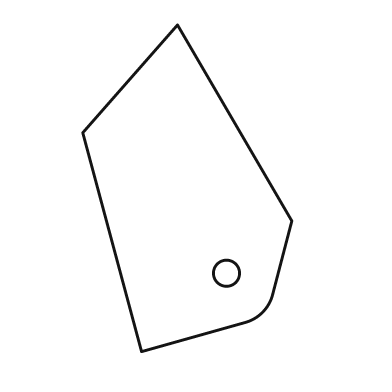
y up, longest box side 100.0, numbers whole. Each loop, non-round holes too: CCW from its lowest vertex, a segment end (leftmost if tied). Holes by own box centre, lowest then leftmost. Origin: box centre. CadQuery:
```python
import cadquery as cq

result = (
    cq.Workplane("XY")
    .moveTo(-14.0, -50.0)
    .lineTo(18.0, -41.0)
    .threePointArc((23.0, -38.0), (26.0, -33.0))
    .lineTo(32.0, -10.0)
    .lineTo(-3.0, 50.0)
    .lineTo(-32.0, 17.0)
    .close()
    .moveTo(12.0, -26.0)
    .circle(4.0)
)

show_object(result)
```